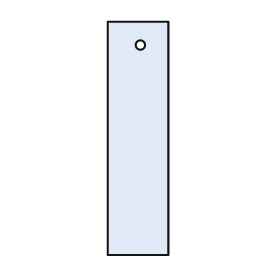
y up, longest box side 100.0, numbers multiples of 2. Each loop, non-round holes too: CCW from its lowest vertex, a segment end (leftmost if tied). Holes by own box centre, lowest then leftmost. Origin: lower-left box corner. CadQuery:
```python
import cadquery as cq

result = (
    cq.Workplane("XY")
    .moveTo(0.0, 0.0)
    .lineTo(26.0, 0.0)
    .lineTo(26.0, 100.0)
    .lineTo(0.0, 100.0)
    .close()
    .moveTo(14.0, 90.0)
    .circle(2.0)
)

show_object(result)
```